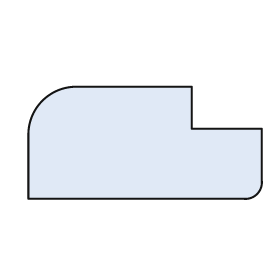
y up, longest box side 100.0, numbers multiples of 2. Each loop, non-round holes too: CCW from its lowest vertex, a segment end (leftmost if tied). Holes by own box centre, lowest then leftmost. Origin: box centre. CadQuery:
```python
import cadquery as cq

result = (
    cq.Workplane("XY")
    .moveTo(-50.0, -24.0)
    .lineTo(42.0, -24.0)
    .threePointArc((48.0, -22.0), (50.0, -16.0))
    .lineTo(50.0, 6.0)
    .lineTo(20.0, 6.0)
    .lineTo(20.0, 24.0)
    .lineTo(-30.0, 24.0)
    .threePointArc((-44.0, 18.0), (-50.0, 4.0))
    .close()
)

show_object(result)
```